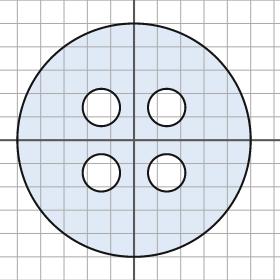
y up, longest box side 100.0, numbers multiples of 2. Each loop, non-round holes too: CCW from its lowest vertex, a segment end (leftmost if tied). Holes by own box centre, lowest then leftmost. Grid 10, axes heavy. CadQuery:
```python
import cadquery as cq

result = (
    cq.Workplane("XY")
    .moveTo(0.0, 0.0)
    .circle(50.0)
    .moveTo(-14.0, -14.0)
    .circle(8.0)
    .moveTo(14.0, -14.0)
    .circle(8.0)
    .moveTo(-14.0, 14.0)
    .circle(8.0)
    .moveTo(14.0, 14.0)
    .circle(8.0)
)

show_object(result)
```